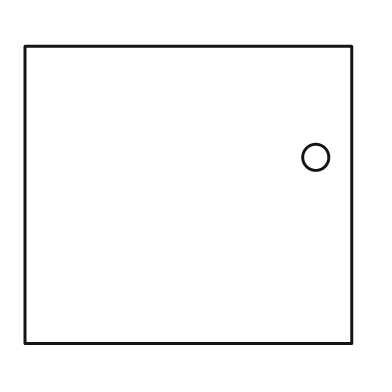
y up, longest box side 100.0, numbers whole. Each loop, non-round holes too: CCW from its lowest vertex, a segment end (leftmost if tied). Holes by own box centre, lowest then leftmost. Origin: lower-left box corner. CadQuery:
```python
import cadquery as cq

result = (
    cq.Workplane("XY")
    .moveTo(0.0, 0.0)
    .lineTo(100.0, 0.0)
    .lineTo(100.0, 91.0)
    .lineTo(0.0, 91.0)
    .close()
    .moveTo(89.0, 57.0)
    .circle(4.0)
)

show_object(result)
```